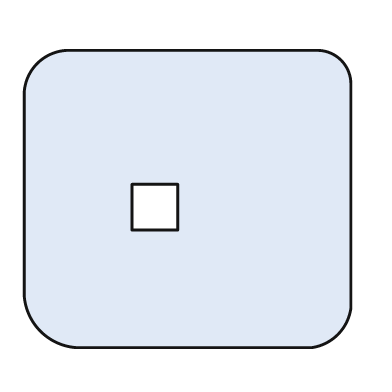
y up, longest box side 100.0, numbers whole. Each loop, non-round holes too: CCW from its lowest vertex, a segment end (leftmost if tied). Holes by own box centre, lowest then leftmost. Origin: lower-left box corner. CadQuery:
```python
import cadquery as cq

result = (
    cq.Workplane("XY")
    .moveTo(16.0, 0.0)
    .lineTo(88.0, 0.0)
    .threePointArc((96.0, 4.0), (100.0, 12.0))
    .lineTo(100.0, 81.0)
    .threePointArc((97.0, 88.0), (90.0, 91.0))
    .lineTo(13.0, 91.0)
    .threePointArc((4.0, 87.0), (0.0, 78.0))
    .lineTo(0.0, 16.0)
    .threePointArc((5.0, 5.0), (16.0, 0.0))
    .close()
    .moveTo(33.0, 36.0)
    .lineTo(47.0, 36.0)
    .lineTo(47.0, 50.0)
    .lineTo(33.0, 50.0)
    .close()
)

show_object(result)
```